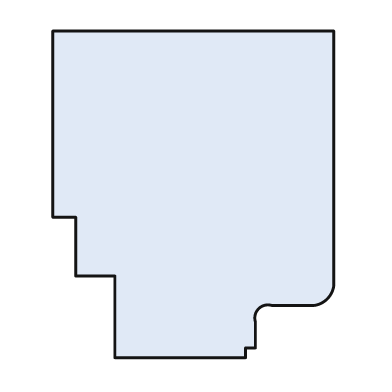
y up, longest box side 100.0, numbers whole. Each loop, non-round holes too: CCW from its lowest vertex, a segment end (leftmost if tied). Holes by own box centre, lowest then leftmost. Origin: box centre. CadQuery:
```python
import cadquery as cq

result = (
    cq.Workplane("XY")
    .moveTo(-24.0, -50.0)
    .lineTo(16.0, -50.0)
    .lineTo(16.0, -47.0)
    .lineTo(19.0, -47.0)
    .lineTo(19.0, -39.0)
    .threePointArc((20.0, -35.0), (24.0, -34.0))
    .lineTo(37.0, -34.0)
    .threePointArc((41.0, -32.0), (43.0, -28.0))
    .lineTo(43.0, 50.0)
    .lineTo(-43.0, 50.0)
    .lineTo(-43.0, -7.0)
    .lineTo(-36.0, -7.0)
    .lineTo(-36.0, -25.0)
    .lineTo(-24.0, -25.0)
    .close()
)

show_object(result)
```